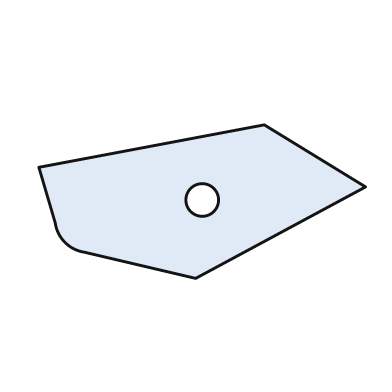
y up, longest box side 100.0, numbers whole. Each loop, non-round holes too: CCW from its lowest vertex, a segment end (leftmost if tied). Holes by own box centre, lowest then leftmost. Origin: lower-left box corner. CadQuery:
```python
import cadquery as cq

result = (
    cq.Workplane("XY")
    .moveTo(48.0, 0.0)
    .lineTo(100.0, 28.0)
    .lineTo(69.0, 47.0)
    .lineTo(0.0, 34.0)
    .lineTo(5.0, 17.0)
    .threePointArc((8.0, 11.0), (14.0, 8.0))
    .close()
    .moveTo(50.0, 24.0)
    .circle(5.0)
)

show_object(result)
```